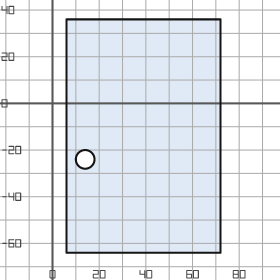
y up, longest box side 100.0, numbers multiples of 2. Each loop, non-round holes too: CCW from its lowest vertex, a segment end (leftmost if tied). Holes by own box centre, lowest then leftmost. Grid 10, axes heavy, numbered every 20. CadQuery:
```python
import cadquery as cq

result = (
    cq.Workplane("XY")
    .moveTo(6.0, -64.0)
    .lineTo(72.0, -64.0)
    .lineTo(72.0, 36.0)
    .lineTo(6.0, 36.0)
    .close()
    .moveTo(14.0, -24.0)
    .circle(4.0)
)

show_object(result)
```